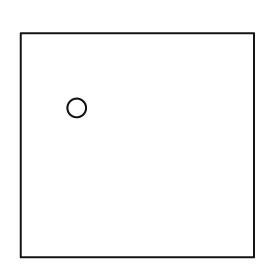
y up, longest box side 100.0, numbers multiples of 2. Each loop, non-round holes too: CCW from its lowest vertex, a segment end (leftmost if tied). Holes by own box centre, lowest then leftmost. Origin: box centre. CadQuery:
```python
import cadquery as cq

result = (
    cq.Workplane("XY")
    .moveTo(-50.0, -48.0)
    .lineTo(50.0, -48.0)
    .lineTo(50.0, 48.0)
    .lineTo(-50.0, 48.0)
    .close()
    .moveTo(-26.0, 16.0)
    .circle(4.0)
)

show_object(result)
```